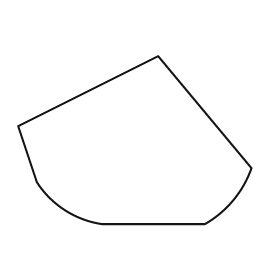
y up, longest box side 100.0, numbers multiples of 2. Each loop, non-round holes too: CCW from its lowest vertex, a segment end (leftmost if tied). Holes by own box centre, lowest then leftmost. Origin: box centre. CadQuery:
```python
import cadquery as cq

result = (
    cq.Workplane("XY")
    .moveTo(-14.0, -36.0)
    .lineTo(30.0, -36.0)
    .threePointArc((42.0, -26.0), (50.0, -12.0))
    .lineTo(10.0, 36.0)
    .lineTo(-50.0, 6.0)
    .lineTo(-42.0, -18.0)
    .threePointArc((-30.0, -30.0), (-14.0, -36.0))
    .close()
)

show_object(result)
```